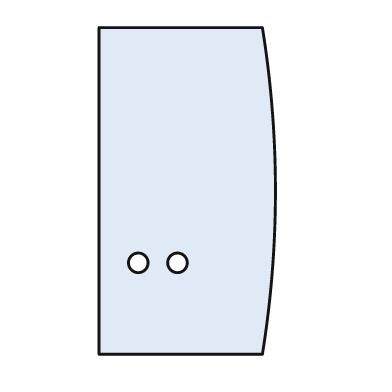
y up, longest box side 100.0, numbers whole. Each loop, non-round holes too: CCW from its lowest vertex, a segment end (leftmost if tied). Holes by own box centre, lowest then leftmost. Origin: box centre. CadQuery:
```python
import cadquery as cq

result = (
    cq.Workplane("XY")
    .moveTo(-27.0, -50.0)
    .lineTo(23.0, -50.0)
    .threePointArc((27.0, 0.0), (23.0, 50.0))
    .lineTo(-27.0, 50.0)
    .close()
    .moveTo(-15.0, -22.0)
    .circle(3.0)
    .moveTo(-3.0, -22.0)
    .circle(3.0)
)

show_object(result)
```